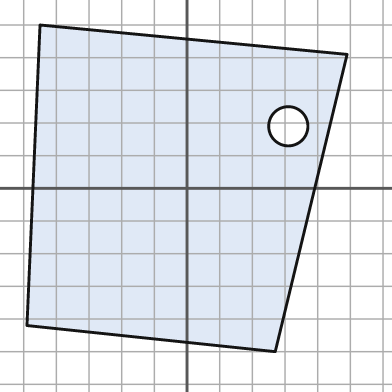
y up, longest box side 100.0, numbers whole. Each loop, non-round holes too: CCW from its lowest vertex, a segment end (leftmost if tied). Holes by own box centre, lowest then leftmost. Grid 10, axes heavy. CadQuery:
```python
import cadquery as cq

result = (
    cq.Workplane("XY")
    .moveTo(27.0, -50.0)
    .lineTo(49.0, 41.0)
    .lineTo(-45.0, 50.0)
    .lineTo(-49.0, -42.0)
    .close()
    .moveTo(31.0, 19.0)
    .circle(6.0)
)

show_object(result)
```